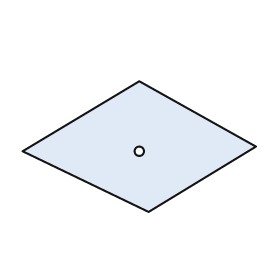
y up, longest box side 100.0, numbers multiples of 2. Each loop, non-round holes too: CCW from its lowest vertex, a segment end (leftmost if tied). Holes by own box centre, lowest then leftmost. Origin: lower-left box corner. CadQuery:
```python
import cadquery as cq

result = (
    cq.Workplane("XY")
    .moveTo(54.0, 0.0)
    .lineTo(100.0, 28.0)
    .lineTo(50.0, 56.0)
    .lineTo(0.0, 26.0)
    .close()
    .moveTo(50.0, 26.0)
    .circle(2.0)
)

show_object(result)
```